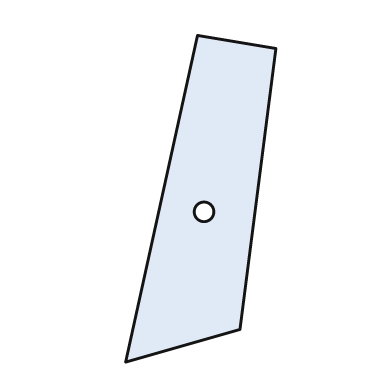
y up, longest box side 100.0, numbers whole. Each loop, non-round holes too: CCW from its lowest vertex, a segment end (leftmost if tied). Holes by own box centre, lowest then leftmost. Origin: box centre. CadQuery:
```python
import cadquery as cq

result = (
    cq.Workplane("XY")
    .moveTo(-23.0, -50.0)
    .lineTo(12.0, -40.0)
    .lineTo(23.0, 46.0)
    .lineTo(-1.0, 50.0)
    .close()
    .moveTo(1.0, -4.0)
    .circle(3.0)
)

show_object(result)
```